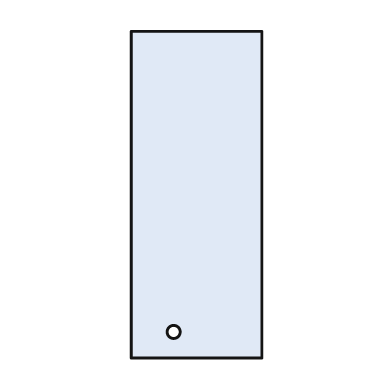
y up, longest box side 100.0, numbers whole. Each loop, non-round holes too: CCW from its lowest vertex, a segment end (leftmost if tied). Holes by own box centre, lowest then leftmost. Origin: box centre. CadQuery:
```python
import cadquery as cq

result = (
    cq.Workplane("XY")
    .moveTo(-20.0, -50.0)
    .lineTo(20.0, -50.0)
    .lineTo(20.0, 50.0)
    .lineTo(-20.0, 50.0)
    .close()
    .moveTo(-7.0, -42.0)
    .circle(2.0)
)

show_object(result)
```